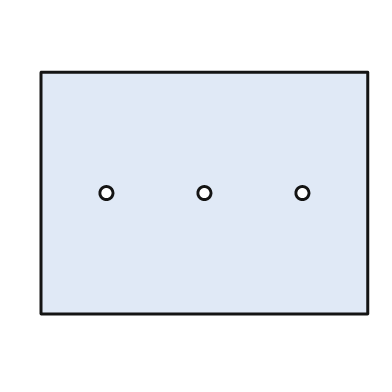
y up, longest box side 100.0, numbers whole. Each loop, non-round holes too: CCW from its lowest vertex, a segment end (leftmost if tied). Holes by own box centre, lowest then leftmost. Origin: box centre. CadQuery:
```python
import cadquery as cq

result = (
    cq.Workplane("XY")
    .moveTo(-50.0, -37.0)
    .lineTo(50.0, -37.0)
    .lineTo(50.0, 37.0)
    .lineTo(-50.0, 37.0)
    .close()
    .moveTo(-30.0, 0.0)
    .circle(2.0)
    .moveTo(0.0, 0.0)
    .circle(2.0)
    .moveTo(30.0, 0.0)
    .circle(2.0)
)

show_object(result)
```